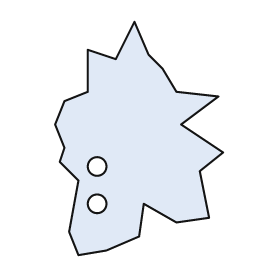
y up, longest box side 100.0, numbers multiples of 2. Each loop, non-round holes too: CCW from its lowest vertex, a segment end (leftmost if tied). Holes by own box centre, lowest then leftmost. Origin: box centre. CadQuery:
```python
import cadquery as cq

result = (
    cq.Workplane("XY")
    .moveTo(-26.0, -50.0)
    .lineTo(-14.0, -48.0)
    .lineTo(0.0, -42.0)
    .lineTo(2.0, -28.0)
    .lineTo(16.0, -36.0)
    .lineTo(30.0, -34.0)
    .lineTo(26.0, -14.0)
    .lineTo(36.0, -6.0)
    .lineTo(18.0, 6.0)
    .lineTo(34.0, 18.0)
    .lineTo(16.0, 20.0)
    .lineTo(10.0, 30.0)
    .lineTo(4.0, 36.0)
    .lineTo(-2.0, 50.0)
    .lineTo(-10.0, 34.0)
    .lineTo(-22.0, 38.0)
    .lineTo(-22.0, 20.0)
    .lineTo(-32.0, 16.0)
    .lineTo(-36.0, 6.0)
    .lineTo(-32.0, -4.0)
    .lineTo(-34.0, -10.0)
    .lineTo(-26.0, -18.0)
    .lineTo(-30.0, -40.0)
    .close()
    .moveTo(-18.0, -28.0)
    .circle(4.0)
    .moveTo(-18.0, -12.0)
    .circle(4.0)
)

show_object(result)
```